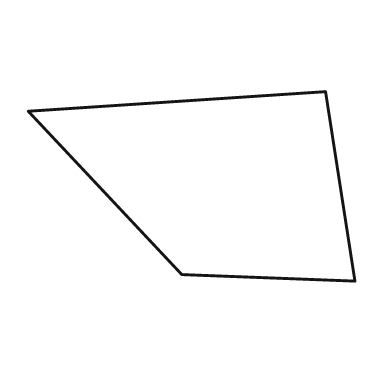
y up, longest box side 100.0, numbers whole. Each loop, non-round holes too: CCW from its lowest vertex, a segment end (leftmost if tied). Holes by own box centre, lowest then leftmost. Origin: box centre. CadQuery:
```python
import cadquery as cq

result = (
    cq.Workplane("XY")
    .moveTo(50.0, -29.0)
    .lineTo(41.0, 29.0)
    .lineTo(-50.0, 23.0)
    .lineTo(-3.0, -27.0)
    .close()
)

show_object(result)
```